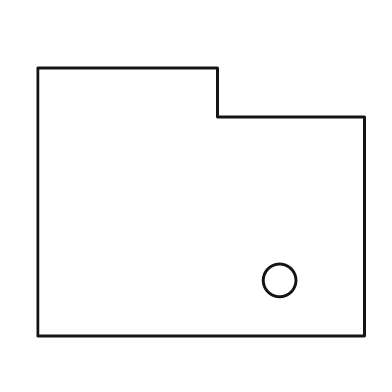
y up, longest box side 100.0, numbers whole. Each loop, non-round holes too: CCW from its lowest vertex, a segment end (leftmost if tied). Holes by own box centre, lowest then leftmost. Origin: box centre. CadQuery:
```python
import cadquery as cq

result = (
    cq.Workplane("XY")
    .moveTo(-50.0, -41.0)
    .lineTo(50.0, -41.0)
    .lineTo(50.0, 26.0)
    .lineTo(5.0, 26.0)
    .lineTo(5.0, 41.0)
    .lineTo(-50.0, 41.0)
    .close()
    .moveTo(24.0, -24.0)
    .circle(5.0)
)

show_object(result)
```